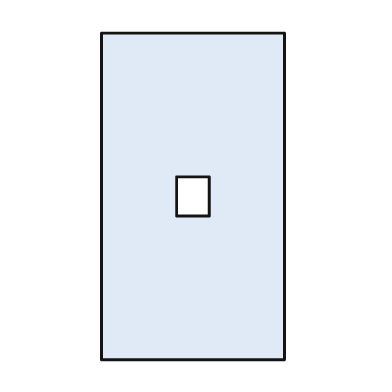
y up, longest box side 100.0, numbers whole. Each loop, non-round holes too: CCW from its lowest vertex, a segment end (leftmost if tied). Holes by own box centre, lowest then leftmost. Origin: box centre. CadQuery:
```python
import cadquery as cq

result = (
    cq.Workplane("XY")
    .moveTo(-28.0, -50.0)
    .lineTo(28.0, -50.0)
    .lineTo(28.0, 50.0)
    .lineTo(-28.0, 50.0)
    .close()
    .moveTo(-5.0, -6.0)
    .lineTo(5.0, -6.0)
    .lineTo(5.0, 6.0)
    .lineTo(-5.0, 6.0)
    .close()
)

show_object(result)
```